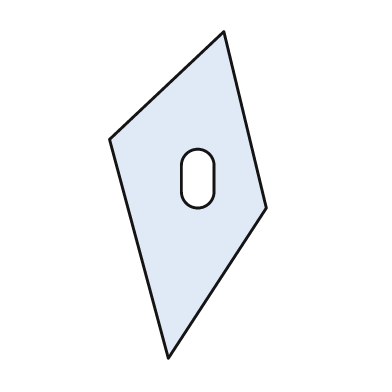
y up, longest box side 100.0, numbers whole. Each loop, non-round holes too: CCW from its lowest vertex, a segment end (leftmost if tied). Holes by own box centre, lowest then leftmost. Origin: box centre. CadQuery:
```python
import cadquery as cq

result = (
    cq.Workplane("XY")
    .moveTo(-6.0, -50.0)
    .lineTo(24.0, -4.0)
    .lineTo(11.0, 50.0)
    .lineTo(-24.0, 17.0)
    .close()
    .moveTo(-2.0, 1.0)
    .threePointArc((3.0, -4.0), (8.0, 1.0))
    .lineTo(8.0, 9.0)
    .threePointArc((3.0, 14.0), (-2.0, 9.0))
    .close()
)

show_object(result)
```